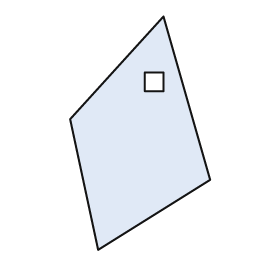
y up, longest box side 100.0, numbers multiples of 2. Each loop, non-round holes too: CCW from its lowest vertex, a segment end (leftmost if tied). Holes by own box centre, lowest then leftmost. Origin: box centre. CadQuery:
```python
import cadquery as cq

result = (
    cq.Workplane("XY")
    .moveTo(-18.0, -50.0)
    .lineTo(30.0, -20.0)
    .lineTo(10.0, 50.0)
    .lineTo(-30.0, 6.0)
    .close()
    .moveTo(2.0, 18.0)
    .lineTo(10.0, 18.0)
    .lineTo(10.0, 26.0)
    .lineTo(2.0, 26.0)
    .close()
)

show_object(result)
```